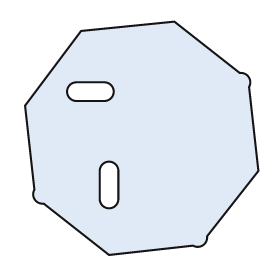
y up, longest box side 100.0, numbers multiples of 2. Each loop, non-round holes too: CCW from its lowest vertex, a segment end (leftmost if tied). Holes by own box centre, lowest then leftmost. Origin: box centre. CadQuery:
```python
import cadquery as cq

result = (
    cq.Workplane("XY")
    .moveTo(-14.0, -50.0)
    .lineTo(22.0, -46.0)
    .threePointArc((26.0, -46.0), (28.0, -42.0))
    .lineTo(50.0, -14.0)
    .lineTo(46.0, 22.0)
    .threePointArc((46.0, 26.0), (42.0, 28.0))
    .lineTo(14.0, 50.0)
    .lineTo(-26.0, 46.0)
    .lineTo(-50.0, 14.0)
    .lineTo(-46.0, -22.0)
    .threePointArc((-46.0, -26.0), (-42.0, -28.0))
    .close()
    .moveTo(-18.0, -26.0)
    .threePointArc((-14.0, -30.0), (-10.0, -26.0))
    .lineTo(-10.0, -14.0)
    .threePointArc((-14.0, -10.0), (-18.0, -14.0))
    .close()
    .moveTo(-28.0, 16.0)
    .lineTo(-16.0, 16.0)
    .threePointArc((-12.0, 20.0), (-16.0, 24.0))
    .lineTo(-28.0, 24.0)
    .threePointArc((-32.0, 20.0), (-28.0, 16.0))
    .close()
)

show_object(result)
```